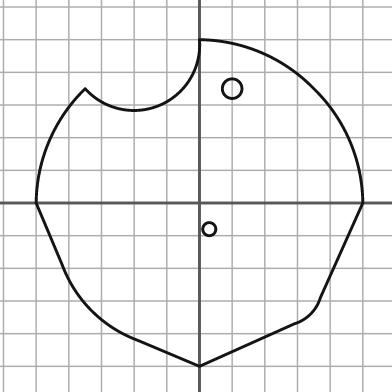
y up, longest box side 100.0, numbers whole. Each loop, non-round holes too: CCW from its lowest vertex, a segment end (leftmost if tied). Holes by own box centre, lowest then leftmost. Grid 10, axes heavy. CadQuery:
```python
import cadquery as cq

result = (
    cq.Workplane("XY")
    .moveTo(0.0, -50.0)
    .lineTo(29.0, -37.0)
    .threePointArc((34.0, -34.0), (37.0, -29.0))
    .lineTo(50.0, 0.0)
    .threePointArc((46.0, 19.0), (35.0, 35.0))
    .threePointArc((19.0, 46.0), (0.0, 50.0))
    .threePointArc((-12.0, 30.0), (-35.0, 35.0))
    .threePointArc((-46.0, 19.0), (-50.0, 0.0))
    .lineTo(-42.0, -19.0)
    .threePointArc((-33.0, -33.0), (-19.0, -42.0))
    .close()
    .moveTo(3.0, -8.0)
    .circle(2.0)
    .moveTo(10.0, 35.0)
    .circle(3.0)
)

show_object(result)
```